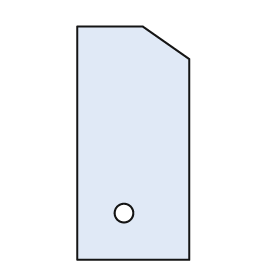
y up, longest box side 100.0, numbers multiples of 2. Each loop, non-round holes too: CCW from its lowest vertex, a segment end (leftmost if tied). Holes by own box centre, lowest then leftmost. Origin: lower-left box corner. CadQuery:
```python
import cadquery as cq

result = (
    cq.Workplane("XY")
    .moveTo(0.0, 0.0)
    .lineTo(48.0, 0.0)
    .lineTo(48.0, 86.0)
    .lineTo(28.0, 100.0)
    .lineTo(0.0, 100.0)
    .close()
    .moveTo(20.0, 20.0)
    .circle(4.0)
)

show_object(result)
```